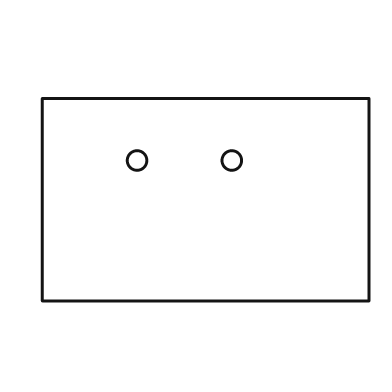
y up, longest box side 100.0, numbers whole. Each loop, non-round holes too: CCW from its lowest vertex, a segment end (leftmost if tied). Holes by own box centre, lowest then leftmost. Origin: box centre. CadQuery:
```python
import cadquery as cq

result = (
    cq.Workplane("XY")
    .moveTo(-50.0, -31.0)
    .lineTo(50.0, -31.0)
    .lineTo(50.0, 31.0)
    .lineTo(-50.0, 31.0)
    .close()
    .moveTo(-21.0, 12.0)
    .circle(3.0)
    .moveTo(8.0, 12.0)
    .circle(3.0)
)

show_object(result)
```